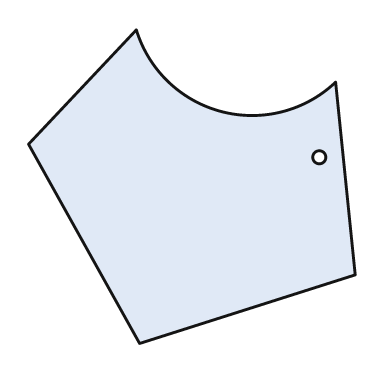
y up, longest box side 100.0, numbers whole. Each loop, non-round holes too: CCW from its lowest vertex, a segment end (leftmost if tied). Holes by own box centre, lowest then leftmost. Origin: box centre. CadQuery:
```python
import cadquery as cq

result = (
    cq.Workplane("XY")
    .moveTo(-16.0, -48.0)
    .lineTo(50.0, -27.0)
    .lineTo(44.0, 32.0)
    .threePointArc((9.0, 23.0), (-17.0, 48.0))
    .lineTo(-50.0, 13.0)
    .close()
    .moveTo(39.0, 9.0)
    .circle(2.0)
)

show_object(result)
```